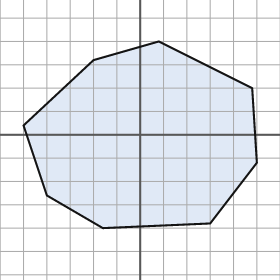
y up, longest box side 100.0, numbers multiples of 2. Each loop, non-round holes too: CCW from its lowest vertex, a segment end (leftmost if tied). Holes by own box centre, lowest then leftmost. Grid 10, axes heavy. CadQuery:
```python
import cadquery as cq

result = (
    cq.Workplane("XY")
    .moveTo(-16.0, -40.0)
    .lineTo(30.0, -38.0)
    .lineTo(50.0, -12.0)
    .lineTo(48.0, 20.0)
    .lineTo(8.0, 40.0)
    .lineTo(-20.0, 32.0)
    .lineTo(-50.0, 4.0)
    .lineTo(-40.0, -26.0)
    .close()
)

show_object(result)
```